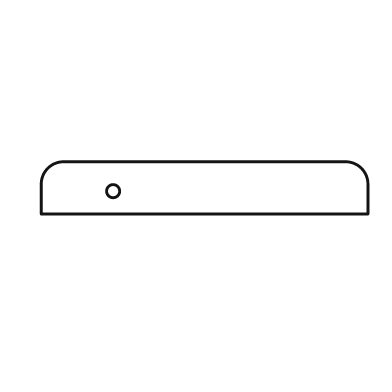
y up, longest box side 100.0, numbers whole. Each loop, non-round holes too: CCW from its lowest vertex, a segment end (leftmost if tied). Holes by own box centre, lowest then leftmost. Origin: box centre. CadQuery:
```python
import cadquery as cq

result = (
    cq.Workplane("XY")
    .moveTo(-50.0, -8.0)
    .lineTo(50.0, -8.0)
    .lineTo(50.0, 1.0)
    .threePointArc((48.0, 6.0), (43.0, 8.0))
    .lineTo(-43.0, 8.0)
    .threePointArc((-48.0, 6.0), (-50.0, 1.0))
    .close()
    .moveTo(-28.0, -1.0)
    .circle(2.0)
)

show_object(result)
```